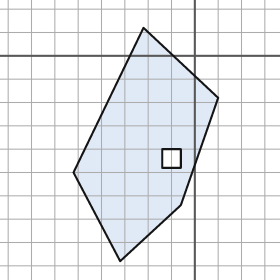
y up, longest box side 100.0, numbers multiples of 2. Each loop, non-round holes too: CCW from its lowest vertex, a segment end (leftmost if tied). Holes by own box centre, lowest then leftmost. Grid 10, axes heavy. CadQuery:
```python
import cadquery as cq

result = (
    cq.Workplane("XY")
    .moveTo(-32.0, -88.0)
    .lineTo(-6.0, -64.0)
    .lineTo(10.0, -18.0)
    .lineTo(-22.0, 12.0)
    .lineTo(-52.0, -50.0)
    .close()
    .moveTo(-14.0, -48.0)
    .lineTo(-6.0, -48.0)
    .lineTo(-6.0, -40.0)
    .lineTo(-14.0, -40.0)
    .close()
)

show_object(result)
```